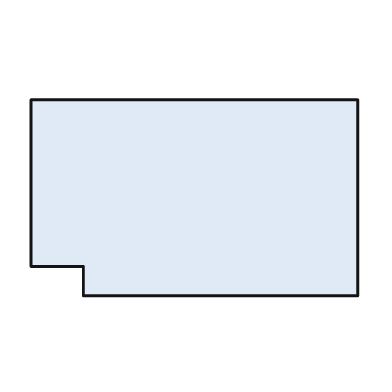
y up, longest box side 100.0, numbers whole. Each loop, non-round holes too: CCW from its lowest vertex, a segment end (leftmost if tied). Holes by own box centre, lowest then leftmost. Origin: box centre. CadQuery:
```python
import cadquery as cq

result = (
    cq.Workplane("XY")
    .moveTo(-34.0, -30.0)
    .lineTo(50.0, -30.0)
    .lineTo(50.0, 30.0)
    .lineTo(-50.0, 30.0)
    .lineTo(-50.0, -21.0)
    .lineTo(-34.0, -21.0)
    .close()
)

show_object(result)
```